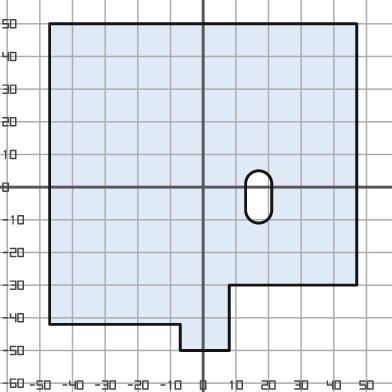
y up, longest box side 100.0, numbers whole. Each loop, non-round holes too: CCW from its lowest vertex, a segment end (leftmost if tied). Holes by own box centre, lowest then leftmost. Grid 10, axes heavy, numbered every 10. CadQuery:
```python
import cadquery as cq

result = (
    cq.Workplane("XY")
    .moveTo(-7.0, -50.0)
    .lineTo(8.0, -50.0)
    .lineTo(8.0, -30.0)
    .lineTo(47.0, -30.0)
    .lineTo(47.0, 50.0)
    .lineTo(-47.0, 50.0)
    .lineTo(-47.0, -42.0)
    .lineTo(-7.0, -42.0)
    .close()
    .moveTo(13.0, -7.0)
    .threePointArc((17.0, -11.0), (21.0, -7.0))
    .lineTo(21.0, 1.0)
    .threePointArc((17.0, 5.0), (13.0, 1.0))
    .close()
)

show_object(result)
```